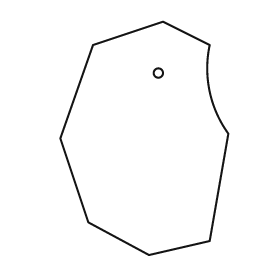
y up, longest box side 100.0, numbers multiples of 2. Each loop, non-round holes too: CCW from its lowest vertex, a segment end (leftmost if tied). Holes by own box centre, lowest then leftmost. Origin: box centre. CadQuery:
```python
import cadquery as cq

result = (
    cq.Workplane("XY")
    .moveTo(2.0, -50.0)
    .lineTo(28.0, -44.0)
    .lineTo(36.0, 2.0)
    .threePointArc((28.0, 20.0), (28.0, 40.0))
    .lineTo(8.0, 50.0)
    .lineTo(-22.0, 40.0)
    .lineTo(-36.0, 0.0)
    .lineTo(-24.0, -36.0)
    .close()
    .moveTo(6.0, 28.0)
    .circle(2.0)
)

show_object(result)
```